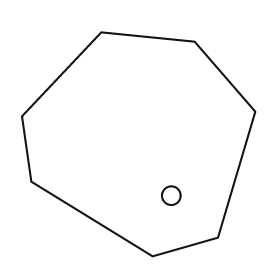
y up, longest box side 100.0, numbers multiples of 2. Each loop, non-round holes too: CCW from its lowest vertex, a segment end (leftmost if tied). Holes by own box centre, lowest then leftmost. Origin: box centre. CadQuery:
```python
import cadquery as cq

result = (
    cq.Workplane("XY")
    .moveTo(6.0, -48.0)
    .lineTo(34.0, -40.0)
    .lineTo(50.0, 14.0)
    .lineTo(24.0, 44.0)
    .lineTo(-16.0, 48.0)
    .lineTo(-50.0, 12.0)
    .lineTo(-46.0, -16.0)
    .close()
    .moveTo(14.0, -22.0)
    .circle(4.0)
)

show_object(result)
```